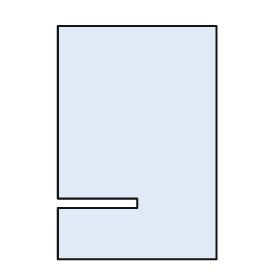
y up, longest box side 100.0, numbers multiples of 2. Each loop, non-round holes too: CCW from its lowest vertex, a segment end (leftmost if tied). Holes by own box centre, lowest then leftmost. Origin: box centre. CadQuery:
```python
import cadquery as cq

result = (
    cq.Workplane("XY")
    .moveTo(-34.0, -50.0)
    .lineTo(34.0, -50.0)
    .lineTo(34.0, 50.0)
    .lineTo(-34.0, 50.0)
    .lineTo(-34.0, -24.0)
    .lineTo(0.0, -24.0)
    .lineTo(0.0, -28.0)
    .lineTo(-34.0, -28.0)
    .close()
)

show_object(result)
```